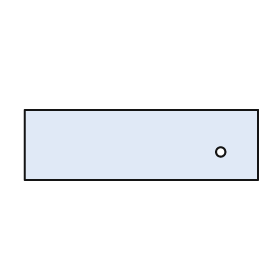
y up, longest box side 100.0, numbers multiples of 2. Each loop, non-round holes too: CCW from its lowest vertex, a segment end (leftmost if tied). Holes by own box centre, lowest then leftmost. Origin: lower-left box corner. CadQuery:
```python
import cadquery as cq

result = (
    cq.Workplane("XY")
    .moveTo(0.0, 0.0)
    .lineTo(100.0, 0.0)
    .lineTo(100.0, 30.0)
    .lineTo(0.0, 30.0)
    .close()
    .moveTo(84.0, 12.0)
    .circle(2.0)
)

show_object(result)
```